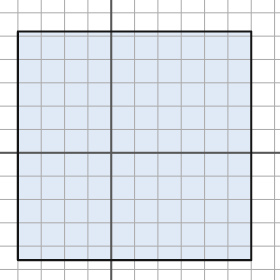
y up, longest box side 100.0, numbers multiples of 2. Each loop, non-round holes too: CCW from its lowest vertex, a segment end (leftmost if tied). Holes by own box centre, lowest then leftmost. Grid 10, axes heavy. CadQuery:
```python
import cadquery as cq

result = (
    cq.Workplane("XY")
    .moveTo(-40.0, -46.0)
    .lineTo(60.0, -46.0)
    .lineTo(60.0, 52.0)
    .lineTo(-40.0, 52.0)
    .close()
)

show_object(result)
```